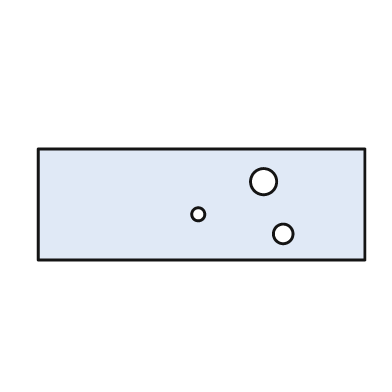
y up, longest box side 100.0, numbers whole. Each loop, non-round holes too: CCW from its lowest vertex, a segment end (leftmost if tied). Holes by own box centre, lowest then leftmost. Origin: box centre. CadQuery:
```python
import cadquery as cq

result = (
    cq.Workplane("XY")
    .moveTo(-50.0, -17.0)
    .lineTo(50.0, -17.0)
    .lineTo(50.0, 17.0)
    .lineTo(-50.0, 17.0)
    .close()
    .moveTo(25.0, -9.0)
    .circle(3.0)
    .moveTo(-1.0, -3.0)
    .circle(2.0)
    .moveTo(19.0, 7.0)
    .circle(4.0)
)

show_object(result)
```